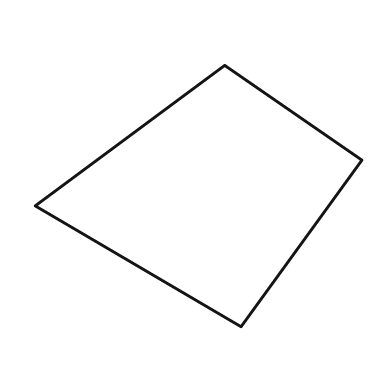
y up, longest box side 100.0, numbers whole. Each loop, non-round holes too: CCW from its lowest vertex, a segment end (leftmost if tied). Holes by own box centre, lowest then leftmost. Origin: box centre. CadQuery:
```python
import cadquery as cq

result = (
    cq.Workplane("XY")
    .moveTo(13.0, -40.0)
    .lineTo(50.0, 11.0)
    .lineTo(8.0, 40.0)
    .lineTo(-50.0, -3.0)
    .close()
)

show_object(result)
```